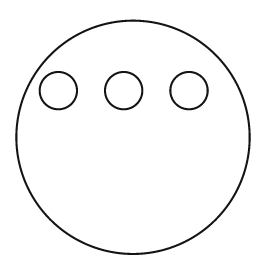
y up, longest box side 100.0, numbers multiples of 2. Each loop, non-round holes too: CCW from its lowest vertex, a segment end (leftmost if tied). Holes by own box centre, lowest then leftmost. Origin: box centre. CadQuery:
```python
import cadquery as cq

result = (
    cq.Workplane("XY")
    .moveTo(0.0, 0.0)
    .circle(50.0)
    .moveTo(-32.0, 20.0)
    .circle(8.0)
    .moveTo(-4.0, 20.0)
    .circle(8.0)
    .moveTo(24.0, 20.0)
    .circle(8.0)
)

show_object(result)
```